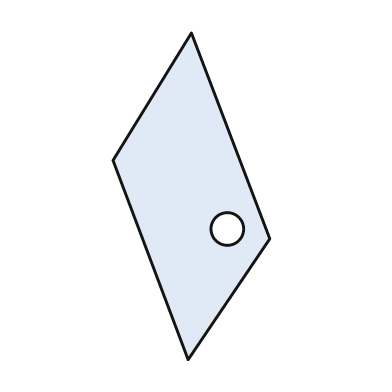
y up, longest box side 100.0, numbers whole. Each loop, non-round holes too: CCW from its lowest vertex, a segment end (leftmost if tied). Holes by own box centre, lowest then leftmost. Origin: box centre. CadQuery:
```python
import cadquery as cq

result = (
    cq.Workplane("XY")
    .moveTo(-1.0, -50.0)
    .lineTo(24.0, -13.0)
    .lineTo(0.0, 50.0)
    .lineTo(-24.0, 11.0)
    .close()
    .moveTo(11.0, -10.0)
    .circle(5.0)
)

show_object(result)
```